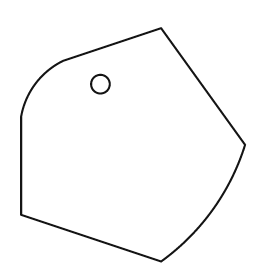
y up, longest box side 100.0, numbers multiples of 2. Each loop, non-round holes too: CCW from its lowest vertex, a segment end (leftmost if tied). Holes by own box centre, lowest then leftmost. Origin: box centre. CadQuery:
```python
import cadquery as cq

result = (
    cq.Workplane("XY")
    .moveTo(12.0, -50.0)
    .threePointArc((34.0, -28.0), (48.0, 0.0))
    .lineTo(12.0, 50.0)
    .lineTo(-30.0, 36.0)
    .threePointArc((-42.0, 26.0), (-48.0, 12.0))
    .lineTo(-48.0, -30.0)
    .close()
    .moveTo(-14.0, 26.0)
    .circle(4.0)
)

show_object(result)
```